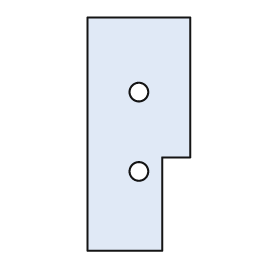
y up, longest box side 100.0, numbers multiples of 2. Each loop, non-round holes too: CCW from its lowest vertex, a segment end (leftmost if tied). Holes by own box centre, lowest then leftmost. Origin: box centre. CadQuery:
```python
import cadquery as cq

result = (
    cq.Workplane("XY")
    .moveTo(-22.0, -50.0)
    .lineTo(10.0, -50.0)
    .lineTo(10.0, -10.0)
    .lineTo(22.0, -10.0)
    .lineTo(22.0, 50.0)
    .lineTo(-22.0, 50.0)
    .close()
    .moveTo(0.0, -16.0)
    .circle(4.0)
    .moveTo(0.0, 18.0)
    .circle(4.0)
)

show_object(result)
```